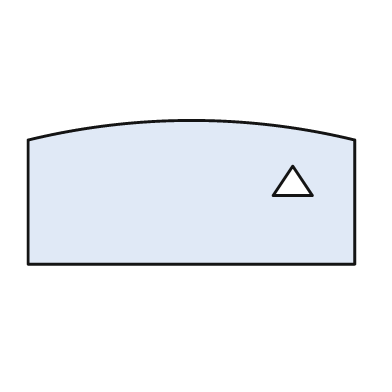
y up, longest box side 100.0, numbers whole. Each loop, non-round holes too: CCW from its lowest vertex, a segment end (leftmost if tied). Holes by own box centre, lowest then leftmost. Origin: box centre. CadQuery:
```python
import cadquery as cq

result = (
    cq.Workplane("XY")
    .moveTo(-50.0, -22.0)
    .lineTo(50.0, -22.0)
    .lineTo(50.0, 16.0)
    .threePointArc((0.0, 22.0), (-50.0, 16.0))
    .close()
    .moveTo(25.0, -1.0)
    .lineTo(37.0, -1.0)
    .lineTo(31.0, 8.0)
    .close()
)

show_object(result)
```